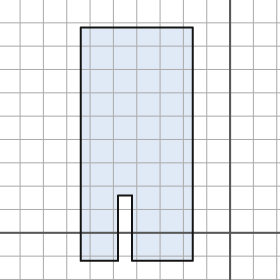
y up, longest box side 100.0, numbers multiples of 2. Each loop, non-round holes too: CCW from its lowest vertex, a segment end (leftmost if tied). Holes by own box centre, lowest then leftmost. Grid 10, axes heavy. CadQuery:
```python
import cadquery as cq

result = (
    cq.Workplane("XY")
    .moveTo(-64.0, -12.0)
    .lineTo(-48.0, -12.0)
    .lineTo(-48.0, 16.0)
    .lineTo(-42.0, 16.0)
    .lineTo(-42.0, -12.0)
    .lineTo(-16.0, -12.0)
    .lineTo(-16.0, 88.0)
    .lineTo(-64.0, 88.0)
    .close()
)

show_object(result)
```